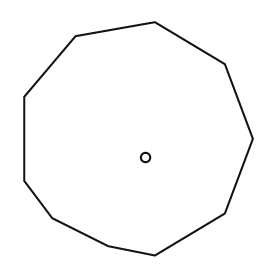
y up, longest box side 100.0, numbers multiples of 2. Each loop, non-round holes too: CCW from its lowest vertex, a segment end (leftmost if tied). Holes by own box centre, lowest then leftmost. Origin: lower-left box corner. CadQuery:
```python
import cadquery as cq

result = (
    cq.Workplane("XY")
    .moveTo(56.0, 0.0)
    .lineTo(86.0, 18.0)
    .lineTo(98.0, 50.0)
    .lineTo(86.0, 82.0)
    .lineTo(56.0, 100.0)
    .lineTo(22.0, 94.0)
    .lineTo(0.0, 68.0)
    .lineTo(0.0, 32.0)
    .lineTo(12.0, 16.0)
    .lineTo(36.0, 4.0)
    .close()
    .moveTo(52.0, 42.0)
    .circle(2.0)
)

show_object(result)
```